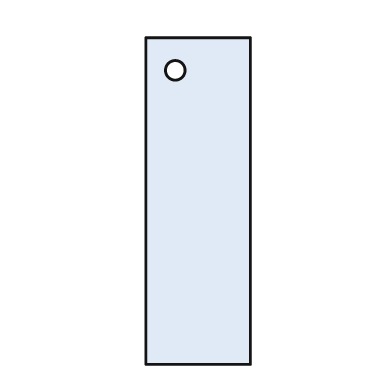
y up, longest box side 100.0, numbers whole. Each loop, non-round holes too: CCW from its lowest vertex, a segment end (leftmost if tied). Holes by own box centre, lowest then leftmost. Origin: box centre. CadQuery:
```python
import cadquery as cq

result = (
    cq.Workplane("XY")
    .moveTo(-16.0, -50.0)
    .lineTo(16.0, -50.0)
    .lineTo(16.0, 50.0)
    .lineTo(-16.0, 50.0)
    .close()
    .moveTo(-7.0, 40.0)
    .circle(3.0)
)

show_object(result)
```